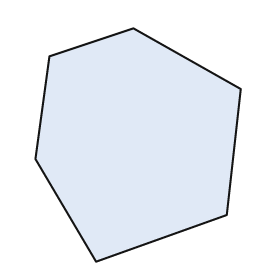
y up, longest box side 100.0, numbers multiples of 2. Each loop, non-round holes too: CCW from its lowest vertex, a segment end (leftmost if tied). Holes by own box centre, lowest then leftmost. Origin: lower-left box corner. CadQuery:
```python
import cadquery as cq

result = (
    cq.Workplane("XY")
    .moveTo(26.0, 0.0)
    .lineTo(82.0, 20.0)
    .lineTo(88.0, 74.0)
    .lineTo(42.0, 100.0)
    .lineTo(6.0, 88.0)
    .lineTo(0.0, 44.0)
    .close()
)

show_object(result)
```